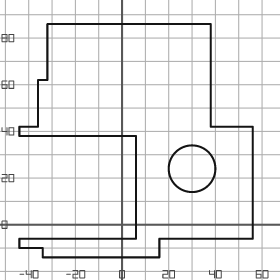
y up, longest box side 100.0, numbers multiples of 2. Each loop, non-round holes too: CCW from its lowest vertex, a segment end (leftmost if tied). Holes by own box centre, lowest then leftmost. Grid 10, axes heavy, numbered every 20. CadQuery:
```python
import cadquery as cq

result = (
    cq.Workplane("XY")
    .moveTo(-34.0, -14.0)
    .lineTo(16.0, -14.0)
    .lineTo(16.0, -6.0)
    .lineTo(56.0, -6.0)
    .lineTo(56.0, 42.0)
    .lineTo(38.0, 42.0)
    .lineTo(38.0, 86.0)
    .lineTo(-32.0, 86.0)
    .lineTo(-32.0, 62.0)
    .lineTo(-36.0, 62.0)
    .lineTo(-36.0, 42.0)
    .lineTo(-44.0, 42.0)
    .lineTo(-44.0, 38.0)
    .lineTo(6.0, 38.0)
    .lineTo(6.0, -6.0)
    .lineTo(-44.0, -6.0)
    .lineTo(-44.0, -10.0)
    .lineTo(-34.0, -10.0)
    .close()
    .moveTo(30.0, 24.0)
    .circle(10.0)
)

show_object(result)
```